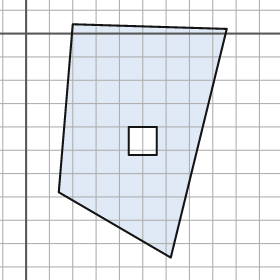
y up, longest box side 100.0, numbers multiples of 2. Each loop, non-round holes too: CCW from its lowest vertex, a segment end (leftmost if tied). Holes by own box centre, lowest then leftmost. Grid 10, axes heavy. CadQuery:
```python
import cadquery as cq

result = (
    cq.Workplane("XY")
    .moveTo(62.0, -96.0)
    .lineTo(86.0, 2.0)
    .lineTo(20.0, 4.0)
    .lineTo(14.0, -68.0)
    .close()
    .moveTo(44.0, -52.0)
    .lineTo(56.0, -52.0)
    .lineTo(56.0, -40.0)
    .lineTo(44.0, -40.0)
    .close()
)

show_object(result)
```